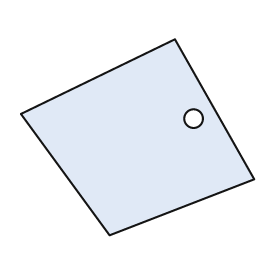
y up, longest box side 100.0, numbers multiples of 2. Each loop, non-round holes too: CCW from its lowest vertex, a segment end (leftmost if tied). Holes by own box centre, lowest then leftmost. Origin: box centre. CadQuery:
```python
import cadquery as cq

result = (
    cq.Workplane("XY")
    .moveTo(-12.0, -42.0)
    .lineTo(50.0, -18.0)
    .lineTo(16.0, 42.0)
    .lineTo(-50.0, 10.0)
    .close()
    .moveTo(24.0, 8.0)
    .circle(4.0)
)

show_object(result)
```